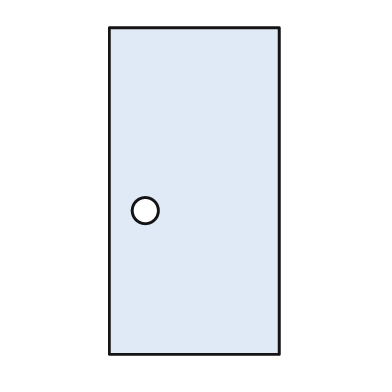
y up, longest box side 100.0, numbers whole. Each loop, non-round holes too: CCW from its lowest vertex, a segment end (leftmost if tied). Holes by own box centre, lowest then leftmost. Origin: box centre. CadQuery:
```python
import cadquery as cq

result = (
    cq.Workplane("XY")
    .moveTo(-26.0, -50.0)
    .lineTo(26.0, -50.0)
    .lineTo(26.0, 50.0)
    .lineTo(-26.0, 50.0)
    .close()
    .moveTo(-15.0, -6.0)
    .circle(4.0)
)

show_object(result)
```